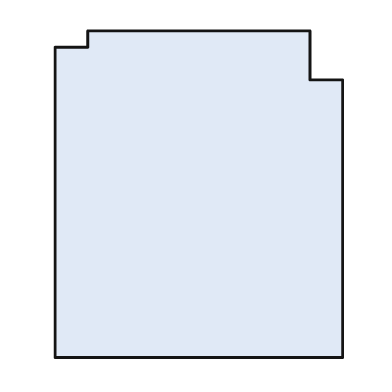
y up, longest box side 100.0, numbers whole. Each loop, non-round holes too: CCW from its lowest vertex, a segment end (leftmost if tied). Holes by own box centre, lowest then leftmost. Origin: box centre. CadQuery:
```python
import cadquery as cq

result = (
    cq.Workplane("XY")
    .moveTo(-44.0, -50.0)
    .lineTo(44.0, -50.0)
    .lineTo(44.0, 35.0)
    .lineTo(34.0, 35.0)
    .lineTo(34.0, 50.0)
    .lineTo(-34.0, 50.0)
    .lineTo(-34.0, 45.0)
    .lineTo(-44.0, 45.0)
    .close()
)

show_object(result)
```